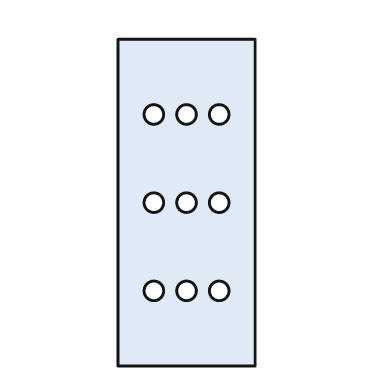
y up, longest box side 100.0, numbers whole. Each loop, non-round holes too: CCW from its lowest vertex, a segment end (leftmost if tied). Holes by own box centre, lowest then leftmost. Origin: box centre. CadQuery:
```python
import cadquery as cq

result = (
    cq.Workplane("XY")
    .moveTo(-21.0, -50.0)
    .lineTo(21.0, -50.0)
    .lineTo(21.0, 50.0)
    .lineTo(-21.0, 50.0)
    .close()
    .moveTo(-10.0, -27.0)
    .circle(3.0)
    .moveTo(0.0, -27.0)
    .circle(3.0)
    .moveTo(10.0, -27.0)
    .circle(3.0)
    .moveTo(-10.0, 0.0)
    .circle(3.0)
    .moveTo(0.0, 0.0)
    .circle(3.0)
    .moveTo(10.0, 0.0)
    .circle(3.0)
    .moveTo(-10.0, 27.0)
    .circle(3.0)
    .moveTo(0.0, 27.0)
    .circle(3.0)
    .moveTo(10.0, 27.0)
    .circle(3.0)
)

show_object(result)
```